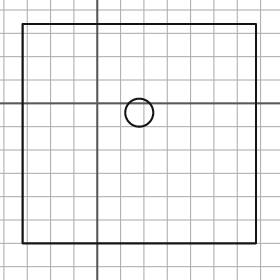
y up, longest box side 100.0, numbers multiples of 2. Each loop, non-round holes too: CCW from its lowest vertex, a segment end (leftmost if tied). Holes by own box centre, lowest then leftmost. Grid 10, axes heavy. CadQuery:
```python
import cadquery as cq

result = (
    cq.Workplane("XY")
    .moveTo(-32.0, -60.0)
    .lineTo(68.0, -60.0)
    .lineTo(68.0, 34.0)
    .lineTo(-32.0, 34.0)
    .close()
    .moveTo(18.0, -4.0)
    .circle(6.0)
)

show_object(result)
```